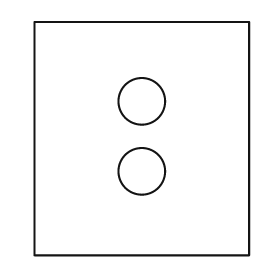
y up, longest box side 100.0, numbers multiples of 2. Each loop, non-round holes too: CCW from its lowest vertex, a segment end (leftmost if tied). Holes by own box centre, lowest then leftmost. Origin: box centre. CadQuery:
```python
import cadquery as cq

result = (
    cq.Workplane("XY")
    .moveTo(-46.0, -50.0)
    .lineTo(46.0, -50.0)
    .lineTo(46.0, 50.0)
    .lineTo(-46.0, 50.0)
    .close()
    .moveTo(0.0, -14.0)
    .circle(10.0)
    .moveTo(0.0, 16.0)
    .circle(10.0)
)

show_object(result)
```